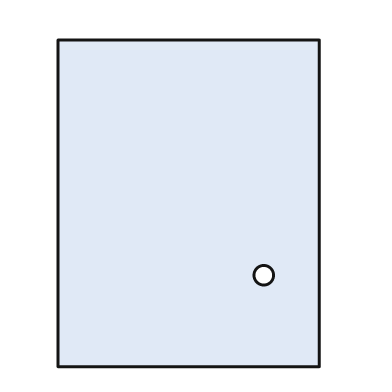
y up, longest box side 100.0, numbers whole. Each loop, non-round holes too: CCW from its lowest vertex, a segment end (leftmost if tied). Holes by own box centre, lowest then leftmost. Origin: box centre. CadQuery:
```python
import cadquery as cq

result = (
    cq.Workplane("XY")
    .moveTo(-40.0, -50.0)
    .lineTo(40.0, -50.0)
    .lineTo(40.0, 50.0)
    .lineTo(-40.0, 50.0)
    .close()
    .moveTo(23.0, -22.0)
    .circle(3.0)
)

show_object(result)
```